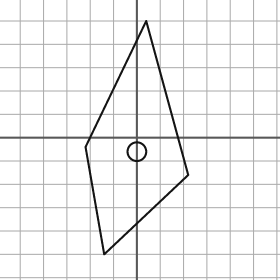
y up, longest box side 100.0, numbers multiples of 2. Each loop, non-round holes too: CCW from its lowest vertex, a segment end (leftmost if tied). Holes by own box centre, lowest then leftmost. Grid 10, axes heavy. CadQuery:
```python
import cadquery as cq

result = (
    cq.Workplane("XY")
    .moveTo(-14.0, -50.0)
    .lineTo(22.0, -16.0)
    .lineTo(4.0, 50.0)
    .lineTo(-22.0, -4.0)
    .close()
    .moveTo(0.0, -6.0)
    .circle(4.0)
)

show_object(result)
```